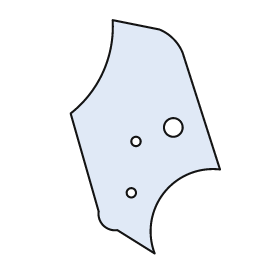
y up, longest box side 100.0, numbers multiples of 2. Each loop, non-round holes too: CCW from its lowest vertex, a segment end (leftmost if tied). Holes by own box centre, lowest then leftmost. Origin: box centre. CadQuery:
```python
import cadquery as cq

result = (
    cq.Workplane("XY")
    .moveTo(4.0, -50.0)
    .threePointArc((8.0, -24.0), (32.0, -14.0))
    .lineTo(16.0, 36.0)
    .threePointArc((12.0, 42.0), (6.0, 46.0))
    .lineTo(-14.0, 50.0)
    .threePointArc((-18.0, 28.0), (-32.0, 10.0))
    .lineTo(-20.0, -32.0)
    .threePointArc((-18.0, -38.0), (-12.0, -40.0))
    .close()
    .moveTo(-6.0, -24.0)
    .circle(2.0)
    .moveTo(-4.0, -2.0)
    .circle(2.0)
    .moveTo(12.0, 4.0)
    .circle(4.0)
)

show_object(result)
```